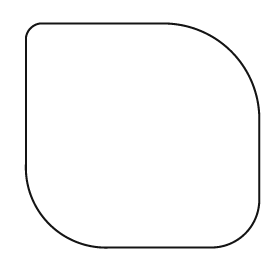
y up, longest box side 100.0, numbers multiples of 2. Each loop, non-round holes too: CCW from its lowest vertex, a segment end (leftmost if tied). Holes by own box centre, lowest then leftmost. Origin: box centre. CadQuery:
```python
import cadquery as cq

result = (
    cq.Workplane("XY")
    .moveTo(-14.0, -48.0)
    .lineTo(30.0, -48.0)
    .threePointArc((44.0, -42.0), (50.0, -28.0))
    .lineTo(50.0, 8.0)
    .threePointArc((38.0, 36.0), (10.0, 48.0))
    .lineTo(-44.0, 48.0)
    .threePointArc((-48.0, 46.0), (-50.0, 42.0))
    .lineTo(-50.0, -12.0)
    .threePointArc((-40.0, -38.0), (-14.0, -48.0))
    .close()
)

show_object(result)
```